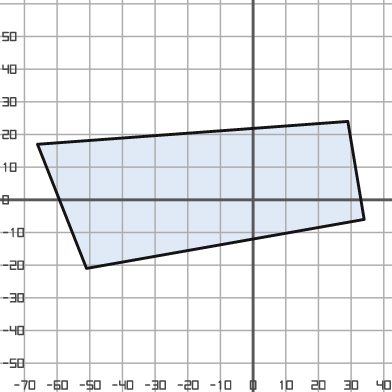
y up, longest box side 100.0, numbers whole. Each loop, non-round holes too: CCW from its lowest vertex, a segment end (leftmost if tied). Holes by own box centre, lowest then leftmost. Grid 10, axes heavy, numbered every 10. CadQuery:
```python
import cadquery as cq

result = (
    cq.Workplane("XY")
    .moveTo(-51.0, -21.0)
    .lineTo(34.0, -6.0)
    .lineTo(29.0, 24.0)
    .lineTo(-66.0, 17.0)
    .close()
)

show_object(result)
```